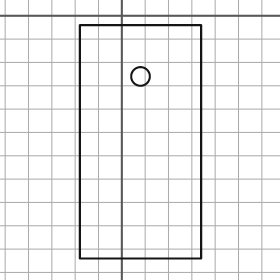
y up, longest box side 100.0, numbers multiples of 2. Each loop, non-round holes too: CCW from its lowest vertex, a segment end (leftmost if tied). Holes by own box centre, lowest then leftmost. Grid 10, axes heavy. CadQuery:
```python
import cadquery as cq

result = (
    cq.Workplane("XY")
    .moveTo(-18.0, -104.0)
    .lineTo(34.0, -104.0)
    .lineTo(34.0, -4.0)
    .lineTo(-18.0, -4.0)
    .close()
    .moveTo(8.0, -26.0)
    .circle(4.0)
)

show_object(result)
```